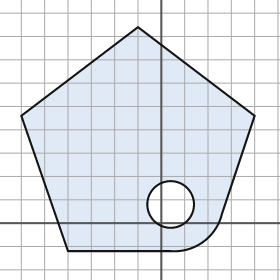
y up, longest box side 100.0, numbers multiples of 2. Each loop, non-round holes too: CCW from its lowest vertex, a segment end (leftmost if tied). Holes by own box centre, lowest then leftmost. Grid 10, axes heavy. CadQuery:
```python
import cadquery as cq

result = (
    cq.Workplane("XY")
    .moveTo(-40.0, -12.0)
    .lineTo(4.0, -12.0)
    .threePointArc((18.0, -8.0), (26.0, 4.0))
    .lineTo(40.0, 46.0)
    .lineTo(-10.0, 84.0)
    .lineTo(-60.0, 46.0)
    .close()
    .moveTo(4.0, 8.0)
    .circle(10.0)
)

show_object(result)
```